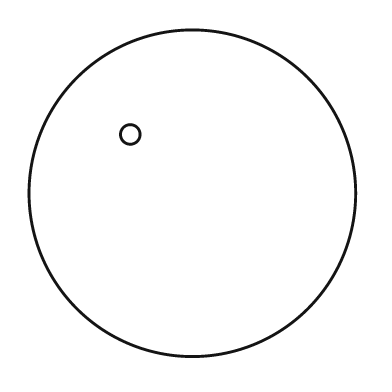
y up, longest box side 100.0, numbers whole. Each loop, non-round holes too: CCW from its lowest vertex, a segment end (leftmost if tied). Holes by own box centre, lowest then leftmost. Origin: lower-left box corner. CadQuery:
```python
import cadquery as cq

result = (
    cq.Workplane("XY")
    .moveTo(50.0, 50.0)
    .circle(50.0)
    .moveTo(31.0, 68.0)
    .circle(3.0)
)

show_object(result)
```